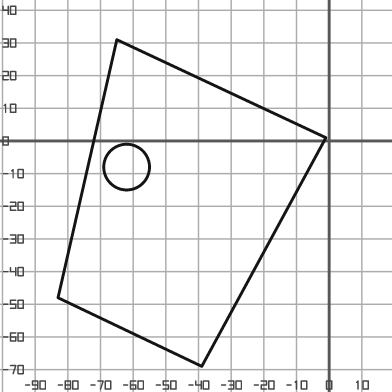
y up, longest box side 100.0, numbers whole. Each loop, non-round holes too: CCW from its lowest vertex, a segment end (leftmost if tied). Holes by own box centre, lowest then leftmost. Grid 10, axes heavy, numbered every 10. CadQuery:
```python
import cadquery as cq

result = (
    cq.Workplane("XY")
    .moveTo(-39.0, -69.0)
    .lineTo(-1.0, 1.0)
    .lineTo(-65.0, 31.0)
    .lineTo(-83.0, -48.0)
    .close()
    .moveTo(-62.0, -8.0)
    .circle(7.0)
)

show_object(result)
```